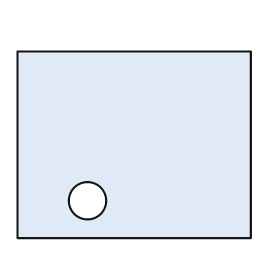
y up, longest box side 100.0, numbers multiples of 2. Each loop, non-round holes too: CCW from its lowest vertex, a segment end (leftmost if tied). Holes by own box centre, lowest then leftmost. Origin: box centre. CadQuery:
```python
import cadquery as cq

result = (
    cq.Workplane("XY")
    .moveTo(-50.0, -40.0)
    .lineTo(50.0, -40.0)
    .lineTo(50.0, 40.0)
    .lineTo(-50.0, 40.0)
    .close()
    .moveTo(-20.0, -24.0)
    .circle(8.0)
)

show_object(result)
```